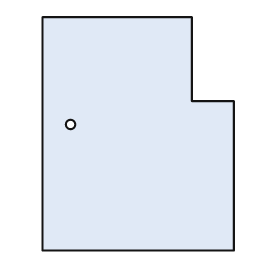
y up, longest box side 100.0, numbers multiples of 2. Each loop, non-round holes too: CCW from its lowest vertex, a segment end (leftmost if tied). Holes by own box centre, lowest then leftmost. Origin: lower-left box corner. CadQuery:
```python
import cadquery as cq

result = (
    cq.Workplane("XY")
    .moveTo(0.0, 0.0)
    .lineTo(82.0, 0.0)
    .lineTo(82.0, 64.0)
    .lineTo(64.0, 64.0)
    .lineTo(64.0, 100.0)
    .lineTo(0.0, 100.0)
    .close()
    .moveTo(12.0, 54.0)
    .circle(2.0)
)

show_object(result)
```